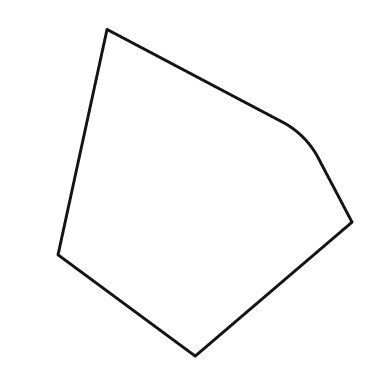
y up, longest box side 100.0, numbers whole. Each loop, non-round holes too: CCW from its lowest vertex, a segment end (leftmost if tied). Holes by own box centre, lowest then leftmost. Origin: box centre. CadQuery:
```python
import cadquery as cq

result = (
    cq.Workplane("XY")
    .moveTo(-3.0, -50.0)
    .lineTo(45.0, -9.0)
    .lineTo(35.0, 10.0)
    .threePointArc((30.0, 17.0), (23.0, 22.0))
    .lineTo(-30.0, 50.0)
    .lineTo(-45.0, -19.0)
    .close()
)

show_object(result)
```